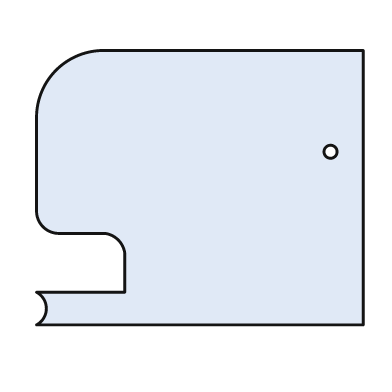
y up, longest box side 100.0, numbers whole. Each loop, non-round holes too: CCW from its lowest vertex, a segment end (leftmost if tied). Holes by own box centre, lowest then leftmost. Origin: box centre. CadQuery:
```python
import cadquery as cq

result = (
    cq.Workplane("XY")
    .moveTo(-50.0, -42.0)
    .lineTo(50.0, -42.0)
    .lineTo(50.0, 42.0)
    .lineTo(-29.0, 42.0)
    .threePointArc((-44.0, 36.0), (-50.0, 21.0))
    .lineTo(-50.0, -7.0)
    .threePointArc((-48.0, -12.0), (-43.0, -14.0))
    .lineTo(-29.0, -14.0)
    .threePointArc((-25.0, -16.0), (-23.0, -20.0))
    .lineTo(-23.0, -32.0)
    .lineTo(-50.0, -32.0)
    .threePointArc((-47.0, -37.0), (-50.0, -42.0))
    .close()
    .moveTo(40.0, 11.0)
    .circle(2.0)
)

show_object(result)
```